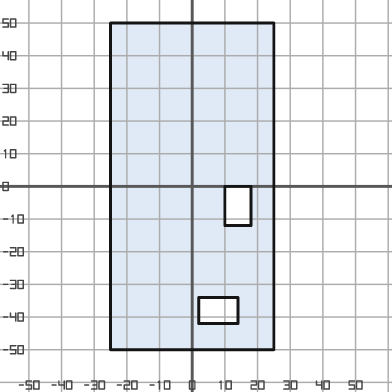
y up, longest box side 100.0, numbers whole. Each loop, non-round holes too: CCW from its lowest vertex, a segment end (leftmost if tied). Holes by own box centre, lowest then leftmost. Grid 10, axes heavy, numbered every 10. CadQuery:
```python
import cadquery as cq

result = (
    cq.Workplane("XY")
    .moveTo(-25.0, -50.0)
    .lineTo(25.0, -50.0)
    .lineTo(25.0, 50.0)
    .lineTo(-25.0, 50.0)
    .close()
    .moveTo(2.0, -42.0)
    .lineTo(14.0, -42.0)
    .lineTo(14.0, -34.0)
    .lineTo(2.0, -34.0)
    .close()
    .moveTo(10.0, -12.0)
    .lineTo(18.0, -12.0)
    .lineTo(18.0, 0.0)
    .lineTo(10.0, 0.0)
    .close()
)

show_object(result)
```